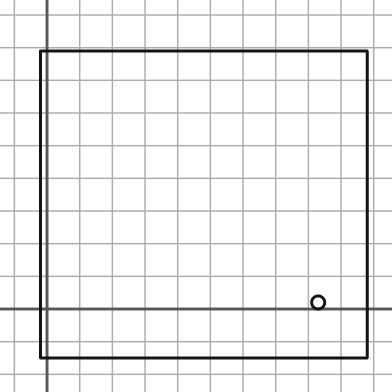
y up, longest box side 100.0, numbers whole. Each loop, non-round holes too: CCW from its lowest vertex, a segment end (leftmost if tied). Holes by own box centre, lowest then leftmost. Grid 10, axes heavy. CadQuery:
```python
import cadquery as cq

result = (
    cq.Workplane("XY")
    .moveTo(-2.0, -15.0)
    .lineTo(98.0, -15.0)
    .lineTo(98.0, 79.0)
    .lineTo(-2.0, 79.0)
    .close()
    .moveTo(83.0, 2.0)
    .circle(2.0)
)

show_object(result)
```